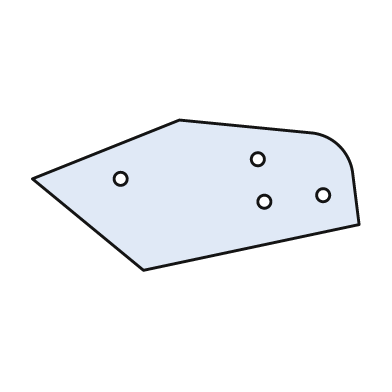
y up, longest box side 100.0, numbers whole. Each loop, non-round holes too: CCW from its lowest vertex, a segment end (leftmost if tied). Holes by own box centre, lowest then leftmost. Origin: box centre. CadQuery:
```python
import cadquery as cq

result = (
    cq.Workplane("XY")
    .moveTo(-16.0, -23.0)
    .lineTo(50.0, -9.0)
    .lineTo(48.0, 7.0)
    .threePointArc((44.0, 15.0), (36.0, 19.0))
    .lineTo(-5.0, 23.0)
    .lineTo(-50.0, 5.0)
    .close()
    .moveTo(21.0, -2.0)
    .circle(2.0)
    .moveTo(39.0, 0.0)
    .circle(2.0)
    .moveTo(-23.0, 5.0)
    .circle(2.0)
    .moveTo(19.0, 11.0)
    .circle(2.0)
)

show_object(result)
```